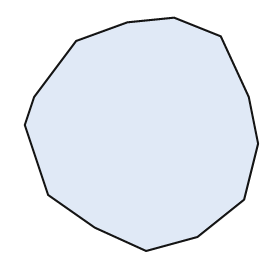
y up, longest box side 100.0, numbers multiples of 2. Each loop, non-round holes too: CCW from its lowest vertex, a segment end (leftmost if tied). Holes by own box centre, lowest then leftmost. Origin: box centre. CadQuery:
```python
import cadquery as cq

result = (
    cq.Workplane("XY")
    .moveTo(2.0, -50.0)
    .lineTo(24.0, -44.0)
    .lineTo(44.0, -28.0)
    .lineTo(50.0, -4.0)
    .lineTo(46.0, 16.0)
    .lineTo(34.0, 42.0)
    .lineTo(14.0, 50.0)
    .lineTo(-6.0, 48.0)
    .lineTo(-28.0, 40.0)
    .lineTo(-46.0, 16.0)
    .lineTo(-50.0, 4.0)
    .lineTo(-40.0, -26.0)
    .lineTo(-20.0, -40.0)
    .close()
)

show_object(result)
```